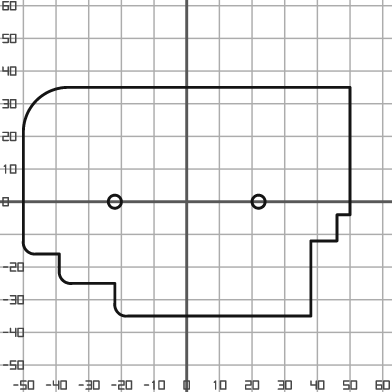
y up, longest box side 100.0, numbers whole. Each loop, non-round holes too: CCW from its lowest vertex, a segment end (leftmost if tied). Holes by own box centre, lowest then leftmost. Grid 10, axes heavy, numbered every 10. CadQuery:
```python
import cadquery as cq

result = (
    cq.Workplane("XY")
    .moveTo(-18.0, -35.0)
    .lineTo(38.0, -35.0)
    .lineTo(38.0, -12.0)
    .lineTo(46.0, -12.0)
    .lineTo(46.0, -4.0)
    .lineTo(50.0, -4.0)
    .lineTo(50.0, 35.0)
    .lineTo(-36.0, 35.0)
    .threePointArc((-46.0, 31.0), (-50.0, 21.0))
    .lineTo(-50.0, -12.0)
    .threePointArc((-49.0, -15.0), (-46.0, -16.0))
    .lineTo(-39.0, -16.0)
    .lineTo(-39.0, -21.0)
    .threePointArc((-38.0, -24.0), (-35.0, -25.0))
    .lineTo(-22.0, -25.0)
    .lineTo(-22.0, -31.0)
    .threePointArc((-21.0, -34.0), (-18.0, -35.0))
    .close()
    .moveTo(-22.0, 0.0)
    .circle(2.0)
    .moveTo(22.0, 0.0)
    .circle(2.0)
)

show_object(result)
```